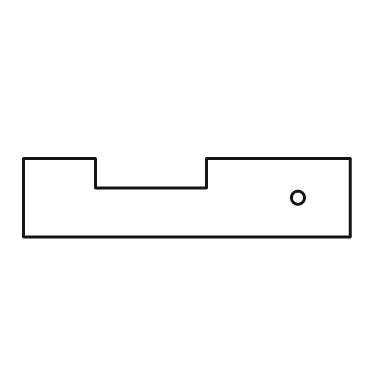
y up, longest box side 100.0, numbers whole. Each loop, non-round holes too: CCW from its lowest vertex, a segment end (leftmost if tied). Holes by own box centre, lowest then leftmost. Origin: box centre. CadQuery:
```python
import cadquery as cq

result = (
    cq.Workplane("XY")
    .moveTo(-50.0, -12.0)
    .lineTo(50.0, -12.0)
    .lineTo(50.0, 12.0)
    .lineTo(6.0, 12.0)
    .lineTo(6.0, 3.0)
    .lineTo(-28.0, 3.0)
    .lineTo(-28.0, 12.0)
    .lineTo(-50.0, 12.0)
    .close()
    .moveTo(34.0, 0.0)
    .circle(2.0)
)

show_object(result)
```